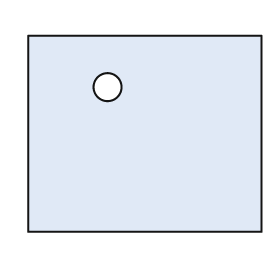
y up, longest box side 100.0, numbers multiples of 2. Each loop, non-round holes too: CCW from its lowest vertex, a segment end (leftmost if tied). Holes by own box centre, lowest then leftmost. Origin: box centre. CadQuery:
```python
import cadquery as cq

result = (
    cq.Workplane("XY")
    .moveTo(-50.0, -42.0)
    .lineTo(50.0, -42.0)
    .lineTo(50.0, 42.0)
    .lineTo(-50.0, 42.0)
    .close()
    .moveTo(-16.0, 20.0)
    .circle(6.0)
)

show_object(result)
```